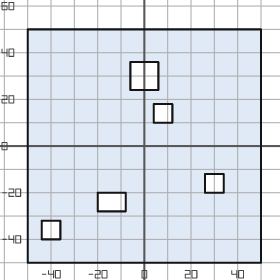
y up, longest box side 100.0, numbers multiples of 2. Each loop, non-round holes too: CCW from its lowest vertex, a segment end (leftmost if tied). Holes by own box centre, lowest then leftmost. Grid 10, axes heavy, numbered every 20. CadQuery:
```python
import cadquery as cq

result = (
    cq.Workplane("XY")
    .moveTo(-50.0, -50.0)
    .lineTo(50.0, -50.0)
    .lineTo(50.0, 50.0)
    .lineTo(-50.0, 50.0)
    .close()
    .moveTo(-44.0, -40.0)
    .lineTo(-36.0, -40.0)
    .lineTo(-36.0, -32.0)
    .lineTo(-44.0, -32.0)
    .close()
    .moveTo(-20.0, -28.0)
    .lineTo(-8.0, -28.0)
    .lineTo(-8.0, -20.0)
    .lineTo(-20.0, -20.0)
    .close()
    .moveTo(26.0, -20.0)
    .lineTo(34.0, -20.0)
    .lineTo(34.0, -12.0)
    .lineTo(26.0, -12.0)
    .close()
    .moveTo(4.0, 10.0)
    .lineTo(12.0, 10.0)
    .lineTo(12.0, 18.0)
    .lineTo(4.0, 18.0)
    .close()
    .moveTo(-6.0, 24.0)
    .lineTo(6.0, 24.0)
    .lineTo(6.0, 36.0)
    .lineTo(-6.0, 36.0)
    .close()
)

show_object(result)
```